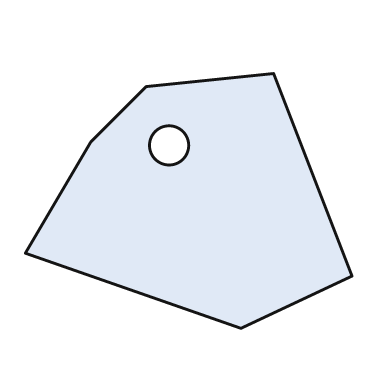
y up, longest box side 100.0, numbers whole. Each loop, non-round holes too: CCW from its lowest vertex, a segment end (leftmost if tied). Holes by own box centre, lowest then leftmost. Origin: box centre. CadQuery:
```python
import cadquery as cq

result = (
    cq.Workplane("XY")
    .moveTo(16.0, -39.0)
    .lineTo(50.0, -23.0)
    .lineTo(26.0, 39.0)
    .lineTo(-13.0, 35.0)
    .lineTo(-30.0, 18.0)
    .lineTo(-50.0, -16.0)
    .close()
    .moveTo(-6.0, 17.0)
    .circle(6.0)
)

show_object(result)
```